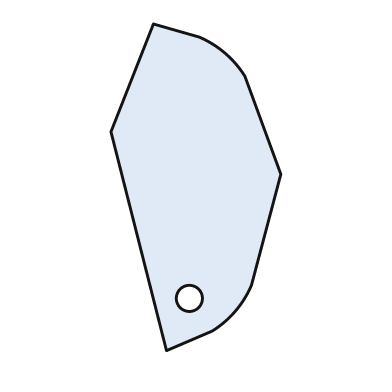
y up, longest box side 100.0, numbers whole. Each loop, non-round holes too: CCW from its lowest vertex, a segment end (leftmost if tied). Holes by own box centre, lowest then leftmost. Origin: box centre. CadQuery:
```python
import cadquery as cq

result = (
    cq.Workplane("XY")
    .moveTo(-9.0, -50.0)
    .lineTo(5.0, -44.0)
    .threePointArc((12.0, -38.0), (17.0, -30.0))
    .lineTo(26.0, 4.0)
    .lineTo(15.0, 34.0)
    .threePointArc((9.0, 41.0), (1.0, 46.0))
    .lineTo(-13.0, 50.0)
    .lineTo(-26.0, 17.0)
    .close()
    .moveTo(-2.0, -34.0)
    .circle(4.0)
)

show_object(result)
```